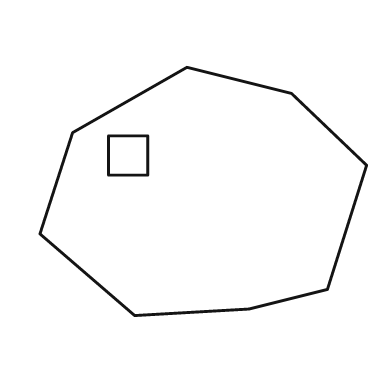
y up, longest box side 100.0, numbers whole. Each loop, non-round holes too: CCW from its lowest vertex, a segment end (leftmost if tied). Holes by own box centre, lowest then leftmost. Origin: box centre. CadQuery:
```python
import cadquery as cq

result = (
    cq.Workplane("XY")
    .moveTo(-21.0, -38.0)
    .lineTo(14.0, -36.0)
    .lineTo(38.0, -30.0)
    .lineTo(50.0, 8.0)
    .lineTo(27.0, 30.0)
    .lineTo(-5.0, 38.0)
    .lineTo(-40.0, 18.0)
    .lineTo(-50.0, -13.0)
    .close()
    .moveTo(-29.0, 5.0)
    .lineTo(-17.0, 5.0)
    .lineTo(-17.0, 17.0)
    .lineTo(-29.0, 17.0)
    .close()
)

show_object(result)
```